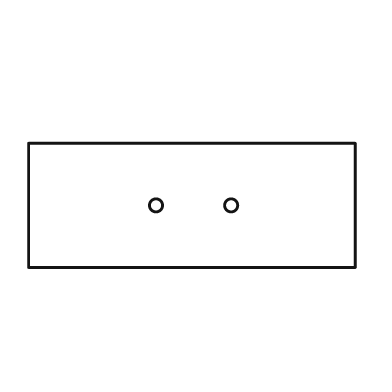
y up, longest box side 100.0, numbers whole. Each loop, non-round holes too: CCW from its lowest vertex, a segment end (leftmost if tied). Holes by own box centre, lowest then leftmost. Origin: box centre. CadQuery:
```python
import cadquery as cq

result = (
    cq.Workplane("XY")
    .moveTo(-50.0, -19.0)
    .lineTo(50.0, -19.0)
    .lineTo(50.0, 19.0)
    .lineTo(-50.0, 19.0)
    .close()
    .moveTo(-11.0, 0.0)
    .circle(2.0)
    .moveTo(12.0, 0.0)
    .circle(2.0)
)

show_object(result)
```